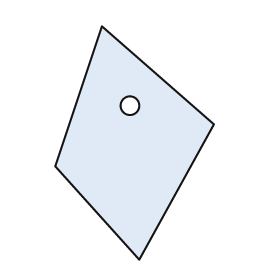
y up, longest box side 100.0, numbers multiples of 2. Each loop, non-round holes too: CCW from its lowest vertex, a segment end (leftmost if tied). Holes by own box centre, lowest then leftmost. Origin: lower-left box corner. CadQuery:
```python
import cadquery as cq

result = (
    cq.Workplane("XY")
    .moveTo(36.0, 0.0)
    .lineTo(68.0, 58.0)
    .lineTo(20.0, 100.0)
    .lineTo(0.0, 40.0)
    .close()
    .moveTo(32.0, 66.0)
    .circle(4.0)
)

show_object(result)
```